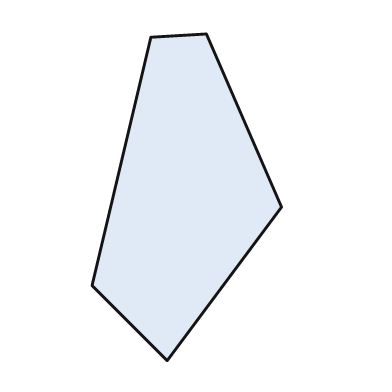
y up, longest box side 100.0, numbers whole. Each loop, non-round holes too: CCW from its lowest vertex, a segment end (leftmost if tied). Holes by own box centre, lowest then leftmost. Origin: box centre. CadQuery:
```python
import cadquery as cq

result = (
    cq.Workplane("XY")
    .moveTo(-6.0, -50.0)
    .lineTo(29.0, -3.0)
    .lineTo(6.0, 50.0)
    .lineTo(-11.0, 49.0)
    .lineTo(-29.0, -27.0)
    .close()
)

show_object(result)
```